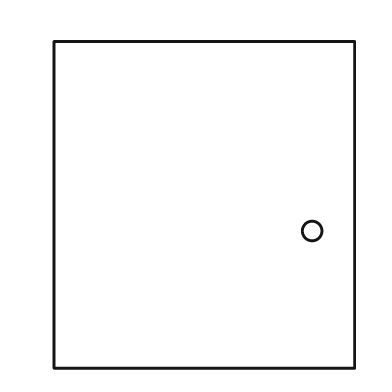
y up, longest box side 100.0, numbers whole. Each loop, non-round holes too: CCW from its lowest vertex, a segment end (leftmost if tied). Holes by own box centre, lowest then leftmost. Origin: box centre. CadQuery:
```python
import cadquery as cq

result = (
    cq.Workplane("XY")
    .moveTo(-46.0, -50.0)
    .lineTo(46.0, -50.0)
    .lineTo(46.0, 50.0)
    .lineTo(-46.0, 50.0)
    .close()
    .moveTo(33.0, -8.0)
    .circle(3.0)
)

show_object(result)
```